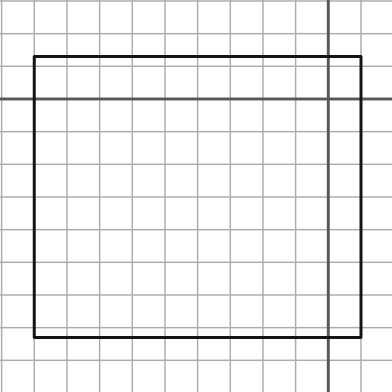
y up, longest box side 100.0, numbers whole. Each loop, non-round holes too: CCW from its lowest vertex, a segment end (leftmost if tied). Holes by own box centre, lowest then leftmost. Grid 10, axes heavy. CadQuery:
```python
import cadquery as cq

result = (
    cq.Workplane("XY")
    .moveTo(-90.0, -73.0)
    .lineTo(10.0, -73.0)
    .lineTo(10.0, 13.0)
    .lineTo(-90.0, 13.0)
    .close()
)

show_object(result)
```